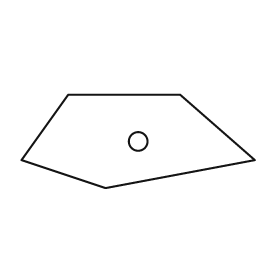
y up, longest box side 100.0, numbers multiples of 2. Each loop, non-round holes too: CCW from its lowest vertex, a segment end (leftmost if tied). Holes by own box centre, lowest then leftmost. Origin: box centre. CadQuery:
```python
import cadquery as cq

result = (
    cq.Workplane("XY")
    .moveTo(-14.0, -20.0)
    .lineTo(50.0, -8.0)
    .lineTo(18.0, 20.0)
    .lineTo(-30.0, 20.0)
    .lineTo(-50.0, -8.0)
    .close()
    .moveTo(0.0, 0.0)
    .circle(4.0)
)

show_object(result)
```